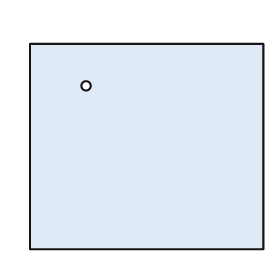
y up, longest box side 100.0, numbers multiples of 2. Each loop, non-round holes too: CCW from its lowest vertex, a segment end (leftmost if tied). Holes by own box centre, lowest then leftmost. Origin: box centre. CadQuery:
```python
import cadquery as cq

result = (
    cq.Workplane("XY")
    .moveTo(-50.0, -44.0)
    .lineTo(50.0, -44.0)
    .lineTo(50.0, 44.0)
    .lineTo(-50.0, 44.0)
    .close()
    .moveTo(-26.0, 26.0)
    .circle(2.0)
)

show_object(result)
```